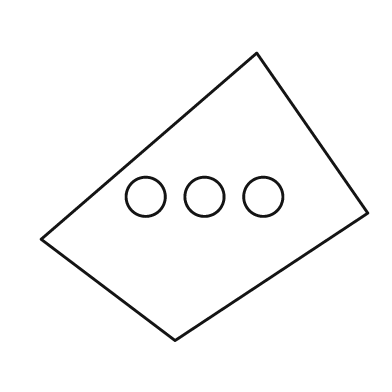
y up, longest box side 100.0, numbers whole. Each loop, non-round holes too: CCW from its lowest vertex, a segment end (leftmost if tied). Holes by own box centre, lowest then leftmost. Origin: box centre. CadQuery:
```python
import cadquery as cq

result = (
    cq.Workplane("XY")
    .moveTo(-9.0, -44.0)
    .lineTo(50.0, -5.0)
    .lineTo(16.0, 44.0)
    .lineTo(-50.0, -13.0)
    .close()
    .moveTo(-18.0, 0.0)
    .circle(6.0)
    .moveTo(0.0, 0.0)
    .circle(6.0)
    .moveTo(18.0, 0.0)
    .circle(6.0)
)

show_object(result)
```